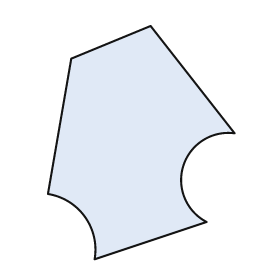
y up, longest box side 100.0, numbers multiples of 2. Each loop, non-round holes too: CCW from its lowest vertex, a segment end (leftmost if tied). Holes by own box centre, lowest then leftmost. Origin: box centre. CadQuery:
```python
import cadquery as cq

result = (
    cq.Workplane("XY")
    .moveTo(-20.0, -50.0)
    .lineTo(28.0, -34.0)
    .threePointArc((18.0, -10.0), (40.0, 4.0))
    .lineTo(4.0, 50.0)
    .lineTo(-30.0, 36.0)
    .lineTo(-40.0, -22.0)
    .threePointArc((-24.0, -32.0), (-20.0, -50.0))
    .close()
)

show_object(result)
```